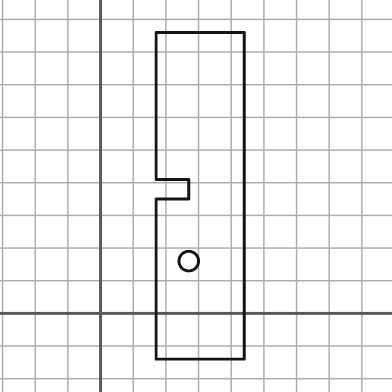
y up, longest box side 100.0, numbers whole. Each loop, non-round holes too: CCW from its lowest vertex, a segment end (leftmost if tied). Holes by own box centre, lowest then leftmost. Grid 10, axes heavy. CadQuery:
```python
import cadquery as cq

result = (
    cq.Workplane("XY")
    .moveTo(17.0, -14.0)
    .lineTo(44.0, -14.0)
    .lineTo(44.0, 86.0)
    .lineTo(17.0, 86.0)
    .lineTo(17.0, 41.0)
    .lineTo(27.0, 41.0)
    .lineTo(27.0, 35.0)
    .lineTo(17.0, 35.0)
    .close()
    .moveTo(27.0, 16.0)
    .circle(3.0)
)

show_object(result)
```